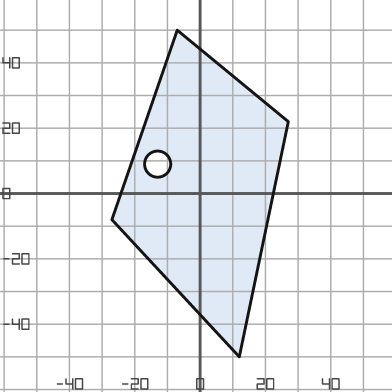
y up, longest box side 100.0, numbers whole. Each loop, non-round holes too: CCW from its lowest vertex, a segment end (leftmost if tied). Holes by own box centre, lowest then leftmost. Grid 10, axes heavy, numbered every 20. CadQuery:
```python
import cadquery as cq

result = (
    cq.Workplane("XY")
    .moveTo(12.0, -50.0)
    .lineTo(27.0, 22.0)
    .lineTo(-7.0, 50.0)
    .lineTo(-27.0, -8.0)
    .close()
    .moveTo(-13.0, 9.0)
    .circle(4.0)
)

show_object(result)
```